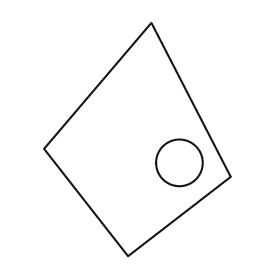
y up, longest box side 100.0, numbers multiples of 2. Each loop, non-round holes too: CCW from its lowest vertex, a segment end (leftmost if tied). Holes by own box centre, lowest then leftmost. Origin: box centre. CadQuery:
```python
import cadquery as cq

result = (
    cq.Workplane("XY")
    .moveTo(-4.0, -50.0)
    .lineTo(40.0, -16.0)
    .lineTo(6.0, 50.0)
    .lineTo(-40.0, -4.0)
    .close()
    .moveTo(18.0, -10.0)
    .circle(10.0)
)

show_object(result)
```